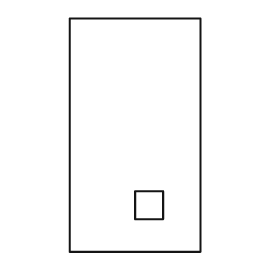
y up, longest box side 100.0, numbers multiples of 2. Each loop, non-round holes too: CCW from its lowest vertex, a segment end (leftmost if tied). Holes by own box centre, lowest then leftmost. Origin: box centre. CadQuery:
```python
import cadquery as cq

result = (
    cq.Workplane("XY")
    .moveTo(-28.0, -50.0)
    .lineTo(28.0, -50.0)
    .lineTo(28.0, 50.0)
    .lineTo(-28.0, 50.0)
    .close()
    .moveTo(0.0, -36.0)
    .lineTo(12.0, -36.0)
    .lineTo(12.0, -24.0)
    .lineTo(0.0, -24.0)
    .close()
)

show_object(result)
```